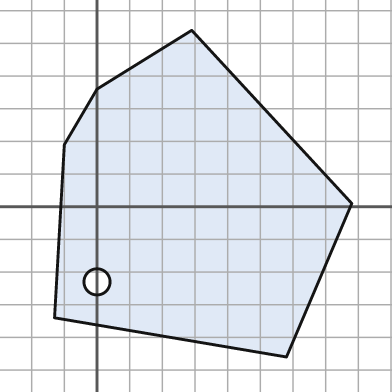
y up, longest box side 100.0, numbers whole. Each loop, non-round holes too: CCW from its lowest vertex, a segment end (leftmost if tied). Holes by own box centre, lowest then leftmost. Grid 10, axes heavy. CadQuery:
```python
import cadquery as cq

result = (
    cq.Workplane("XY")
    .moveTo(58.0, -46.0)
    .lineTo(78.0, 1.0)
    .lineTo(29.0, 54.0)
    .lineTo(0.0, 36.0)
    .lineTo(-10.0, 19.0)
    .lineTo(-13.0, -34.0)
    .close()
    .moveTo(0.0, -23.0)
    .circle(4.0)
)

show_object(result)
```